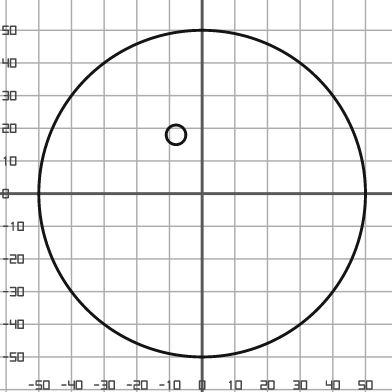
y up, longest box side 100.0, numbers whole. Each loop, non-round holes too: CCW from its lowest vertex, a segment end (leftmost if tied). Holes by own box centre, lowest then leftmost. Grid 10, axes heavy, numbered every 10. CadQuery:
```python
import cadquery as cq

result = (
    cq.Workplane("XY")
    .moveTo(0.0, 0.0)
    .circle(50.0)
    .moveTo(-8.0, 18.0)
    .circle(3.0)
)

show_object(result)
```